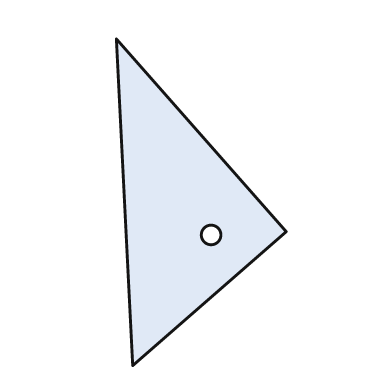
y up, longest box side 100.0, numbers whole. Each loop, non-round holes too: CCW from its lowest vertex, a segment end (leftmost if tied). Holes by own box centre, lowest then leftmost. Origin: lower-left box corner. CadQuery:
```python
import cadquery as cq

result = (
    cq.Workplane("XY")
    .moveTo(5.0, 0.0)
    .lineTo(52.0, 41.0)
    .lineTo(0.0, 100.0)
    .close()
    .moveTo(29.0, 40.0)
    .circle(3.0)
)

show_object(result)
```